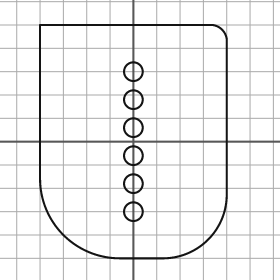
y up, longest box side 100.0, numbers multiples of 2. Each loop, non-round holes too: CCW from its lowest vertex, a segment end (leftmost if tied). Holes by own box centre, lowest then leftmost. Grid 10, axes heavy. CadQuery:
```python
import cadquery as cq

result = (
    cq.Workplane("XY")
    .moveTo(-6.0, -50.0)
    .lineTo(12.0, -50.0)
    .threePointArc((32.0, -42.0), (40.0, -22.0))
    .lineTo(40.0, 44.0)
    .threePointArc((38.0, 48.0), (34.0, 50.0))
    .lineTo(-40.0, 50.0)
    .lineTo(-40.0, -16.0)
    .threePointArc((-30.0, -40.0), (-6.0, -50.0))
    .close()
    .moveTo(0.0, -30.0)
    .circle(4.0)
    .moveTo(0.0, -18.0)
    .circle(4.0)
    .moveTo(0.0, -6.0)
    .circle(4.0)
    .moveTo(0.0, 6.0)
    .circle(4.0)
    .moveTo(0.0, 18.0)
    .circle(4.0)
    .moveTo(0.0, 30.0)
    .circle(4.0)
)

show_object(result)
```